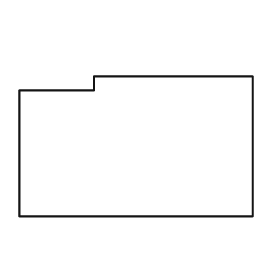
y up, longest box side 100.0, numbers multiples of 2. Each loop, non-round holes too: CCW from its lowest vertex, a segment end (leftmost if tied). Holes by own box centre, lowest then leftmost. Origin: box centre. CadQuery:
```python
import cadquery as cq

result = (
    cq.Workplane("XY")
    .moveTo(-50.0, -30.0)
    .lineTo(50.0, -30.0)
    .lineTo(50.0, 30.0)
    .lineTo(-18.0, 30.0)
    .lineTo(-18.0, 24.0)
    .lineTo(-50.0, 24.0)
    .close()
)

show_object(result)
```